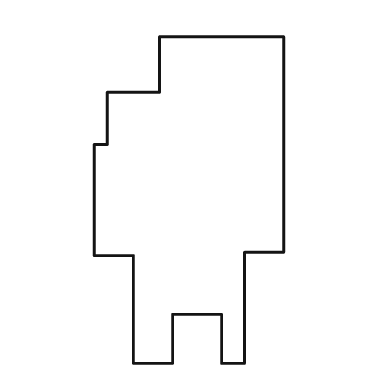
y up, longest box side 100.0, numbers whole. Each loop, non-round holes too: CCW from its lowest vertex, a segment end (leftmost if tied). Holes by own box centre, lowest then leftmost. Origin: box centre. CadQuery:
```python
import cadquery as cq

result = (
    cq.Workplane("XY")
    .moveTo(-17.0, -50.0)
    .lineTo(-5.0, -50.0)
    .lineTo(-5.0, -35.0)
    .lineTo(10.0, -35.0)
    .lineTo(10.0, -50.0)
    .lineTo(17.0, -50.0)
    .lineTo(17.0, -16.0)
    .lineTo(29.0, -16.0)
    .lineTo(29.0, 50.0)
    .lineTo(-9.0, 50.0)
    .lineTo(-9.0, 33.0)
    .lineTo(-25.0, 33.0)
    .lineTo(-25.0, 17.0)
    .lineTo(-29.0, 17.0)
    .lineTo(-29.0, -17.0)
    .lineTo(-17.0, -17.0)
    .close()
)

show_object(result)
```